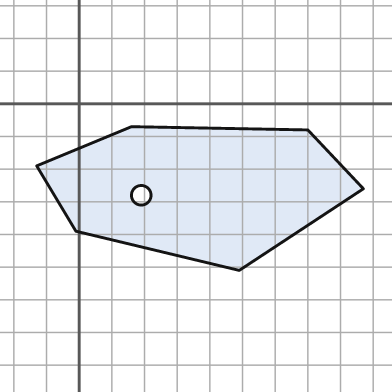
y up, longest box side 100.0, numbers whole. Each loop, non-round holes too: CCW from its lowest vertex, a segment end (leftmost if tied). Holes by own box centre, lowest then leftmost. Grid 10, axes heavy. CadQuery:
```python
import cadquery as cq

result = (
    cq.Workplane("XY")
    .moveTo(49.0, -51.0)
    .lineTo(87.0, -26.0)
    .lineTo(70.0, -8.0)
    .lineTo(16.0, -7.0)
    .lineTo(-13.0, -19.0)
    .lineTo(-1.0, -39.0)
    .close()
    .moveTo(19.0, -28.0)
    .circle(3.0)
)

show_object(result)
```